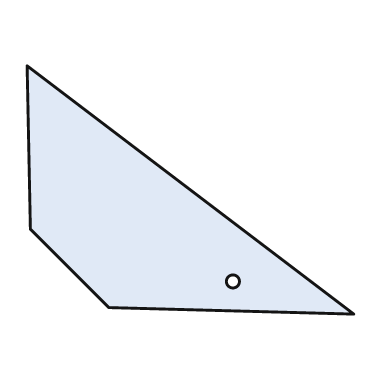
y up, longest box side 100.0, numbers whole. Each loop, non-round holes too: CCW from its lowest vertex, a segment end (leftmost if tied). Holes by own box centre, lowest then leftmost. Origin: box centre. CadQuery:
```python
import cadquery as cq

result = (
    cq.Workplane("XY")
    .moveTo(50.0, -38.0)
    .lineTo(-50.0, 38.0)
    .lineTo(-49.0, -12.0)
    .lineTo(-25.0, -36.0)
    .close()
    .moveTo(13.0, -28.0)
    .circle(2.0)
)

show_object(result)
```